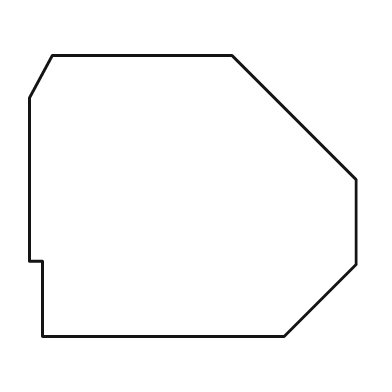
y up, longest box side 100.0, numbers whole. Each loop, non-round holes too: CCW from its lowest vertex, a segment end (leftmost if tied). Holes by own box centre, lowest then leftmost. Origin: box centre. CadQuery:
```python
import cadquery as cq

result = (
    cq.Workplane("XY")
    .moveTo(-46.0, -43.0)
    .lineTo(28.0, -43.0)
    .lineTo(50.0, -21.0)
    .lineTo(50.0, 5.0)
    .lineTo(12.0, 43.0)
    .lineTo(-43.0, 43.0)
    .lineTo(-50.0, 30.0)
    .lineTo(-50.0, -20.0)
    .lineTo(-46.0, -20.0)
    .close()
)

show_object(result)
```